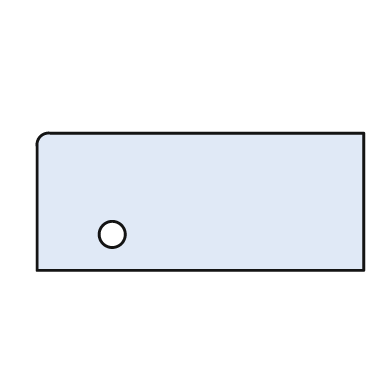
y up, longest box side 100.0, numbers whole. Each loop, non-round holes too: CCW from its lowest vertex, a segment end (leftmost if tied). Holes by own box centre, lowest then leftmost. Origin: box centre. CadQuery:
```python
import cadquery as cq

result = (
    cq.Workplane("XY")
    .moveTo(-50.0, -21.0)
    .lineTo(50.0, -21.0)
    .lineTo(50.0, 21.0)
    .lineTo(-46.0, 21.0)
    .threePointArc((-49.0, 20.0), (-50.0, 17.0))
    .close()
    .moveTo(-27.0, -10.0)
    .circle(4.0)
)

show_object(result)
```